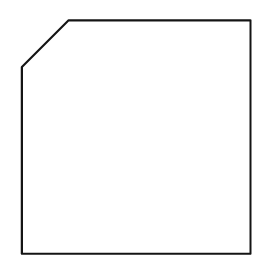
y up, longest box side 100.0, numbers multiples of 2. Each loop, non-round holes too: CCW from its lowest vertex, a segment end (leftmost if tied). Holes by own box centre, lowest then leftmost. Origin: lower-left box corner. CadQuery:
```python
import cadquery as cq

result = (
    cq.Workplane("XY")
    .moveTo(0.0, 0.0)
    .lineTo(98.0, 0.0)
    .lineTo(98.0, 100.0)
    .lineTo(20.0, 100.0)
    .lineTo(0.0, 80.0)
    .close()
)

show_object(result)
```